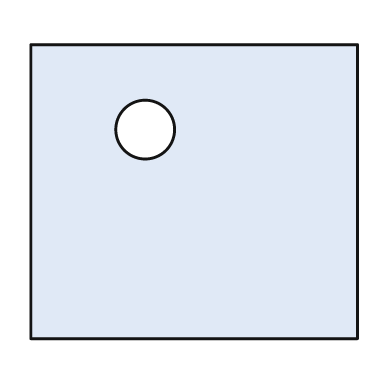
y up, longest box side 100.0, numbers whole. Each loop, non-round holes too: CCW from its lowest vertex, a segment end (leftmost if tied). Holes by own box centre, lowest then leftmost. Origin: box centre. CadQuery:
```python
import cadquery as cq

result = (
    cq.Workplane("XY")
    .moveTo(-50.0, -45.0)
    .lineTo(50.0, -45.0)
    .lineTo(50.0, 45.0)
    .lineTo(-50.0, 45.0)
    .close()
    .moveTo(-15.0, 19.0)
    .circle(9.0)
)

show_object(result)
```